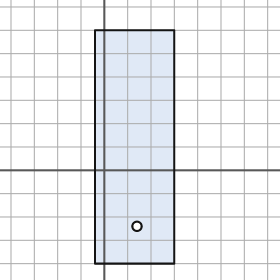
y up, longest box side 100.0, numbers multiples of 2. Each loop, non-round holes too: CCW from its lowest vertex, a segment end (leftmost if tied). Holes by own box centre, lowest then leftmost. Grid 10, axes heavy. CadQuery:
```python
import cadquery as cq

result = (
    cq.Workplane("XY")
    .moveTo(-4.0, -40.0)
    .lineTo(30.0, -40.0)
    .lineTo(30.0, 60.0)
    .lineTo(-4.0, 60.0)
    .close()
    .moveTo(14.0, -24.0)
    .circle(2.0)
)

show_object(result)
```